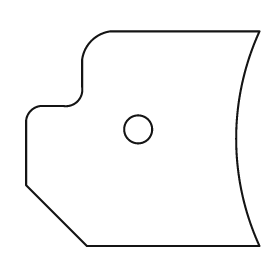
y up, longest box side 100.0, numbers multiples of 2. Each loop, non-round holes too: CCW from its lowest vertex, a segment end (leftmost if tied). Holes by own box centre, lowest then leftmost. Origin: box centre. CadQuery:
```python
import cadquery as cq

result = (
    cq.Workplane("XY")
    .moveTo(-24.0, -46.0)
    .lineTo(50.0, -46.0)
    .threePointArc((40.0, 0.0), (50.0, 46.0))
    .lineTo(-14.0, 46.0)
    .threePointArc((-22.0, 42.0), (-26.0, 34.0))
    .lineTo(-26.0, 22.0)
    .threePointArc((-28.0, 16.0), (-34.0, 14.0))
    .lineTo(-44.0, 14.0)
    .threePointArc((-48.0, 12.0), (-50.0, 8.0))
    .lineTo(-50.0, -20.0)
    .close()
    .moveTo(-2.0, 4.0)
    .circle(6.0)
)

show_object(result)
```